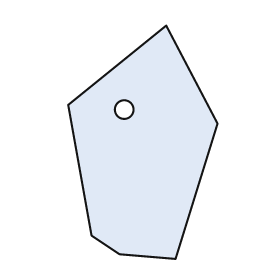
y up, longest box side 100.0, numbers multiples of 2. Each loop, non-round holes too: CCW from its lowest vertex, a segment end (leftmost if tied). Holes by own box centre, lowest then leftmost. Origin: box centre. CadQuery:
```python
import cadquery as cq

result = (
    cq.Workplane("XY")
    .moveTo(14.0, -50.0)
    .lineTo(32.0, 8.0)
    .lineTo(10.0, 50.0)
    .lineTo(-32.0, 16.0)
    .lineTo(-22.0, -40.0)
    .lineTo(-10.0, -48.0)
    .close()
    .moveTo(-8.0, 14.0)
    .circle(4.0)
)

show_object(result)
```